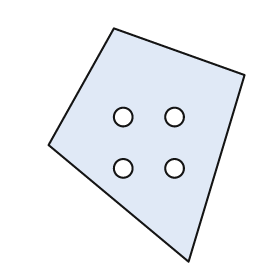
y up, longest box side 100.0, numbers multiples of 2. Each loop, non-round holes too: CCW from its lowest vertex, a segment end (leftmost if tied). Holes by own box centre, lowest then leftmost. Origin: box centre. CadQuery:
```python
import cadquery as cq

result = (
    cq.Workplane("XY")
    .moveTo(18.0, -50.0)
    .lineTo(42.0, 30.0)
    .lineTo(-14.0, 50.0)
    .lineTo(-42.0, 0.0)
    .close()
    .moveTo(-10.0, -10.0)
    .circle(4.0)
    .moveTo(12.0, -10.0)
    .circle(4.0)
    .moveTo(-10.0, 12.0)
    .circle(4.0)
    .moveTo(12.0, 12.0)
    .circle(4.0)
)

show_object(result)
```